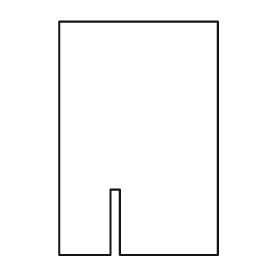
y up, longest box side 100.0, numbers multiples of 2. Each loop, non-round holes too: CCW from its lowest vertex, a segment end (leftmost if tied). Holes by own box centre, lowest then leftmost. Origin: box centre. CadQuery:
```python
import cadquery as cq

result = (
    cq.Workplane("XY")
    .moveTo(-34.0, -50.0)
    .lineTo(-12.0, -50.0)
    .lineTo(-12.0, -22.0)
    .lineTo(-8.0, -22.0)
    .lineTo(-8.0, -50.0)
    .lineTo(34.0, -50.0)
    .lineTo(34.0, 50.0)
    .lineTo(-34.0, 50.0)
    .close()
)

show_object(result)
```